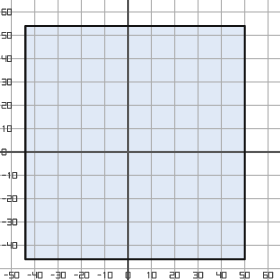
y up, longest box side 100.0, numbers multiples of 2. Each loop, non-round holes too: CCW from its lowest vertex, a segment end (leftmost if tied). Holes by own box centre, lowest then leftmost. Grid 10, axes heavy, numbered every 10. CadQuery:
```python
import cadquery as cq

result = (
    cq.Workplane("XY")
    .moveTo(-44.0, -46.0)
    .lineTo(50.0, -46.0)
    .lineTo(50.0, 54.0)
    .lineTo(-44.0, 54.0)
    .close()
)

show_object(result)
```